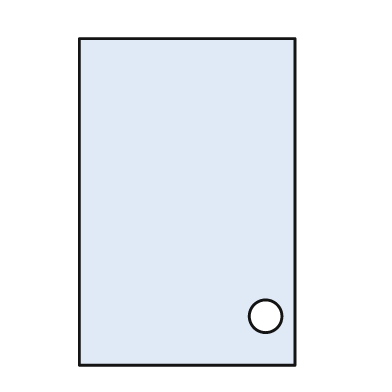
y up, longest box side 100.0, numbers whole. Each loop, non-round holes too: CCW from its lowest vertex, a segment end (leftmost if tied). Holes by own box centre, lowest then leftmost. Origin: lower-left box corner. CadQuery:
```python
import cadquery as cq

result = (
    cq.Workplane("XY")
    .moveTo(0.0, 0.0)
    .lineTo(66.0, 0.0)
    .lineTo(66.0, 100.0)
    .lineTo(0.0, 100.0)
    .close()
    .moveTo(57.0, 15.0)
    .circle(5.0)
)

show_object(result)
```